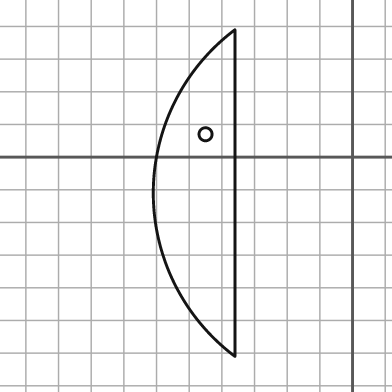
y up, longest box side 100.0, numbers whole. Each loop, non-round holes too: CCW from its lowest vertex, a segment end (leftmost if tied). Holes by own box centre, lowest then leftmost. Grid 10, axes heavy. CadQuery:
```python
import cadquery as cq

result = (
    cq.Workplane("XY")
    .moveTo(-36.0, -61.0)
    .lineTo(-36.0, 39.0)
    .threePointArc((-61.0, -11.0), (-36.0, -61.0))
    .close()
    .moveTo(-45.0, 7.0)
    .circle(2.0)
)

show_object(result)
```